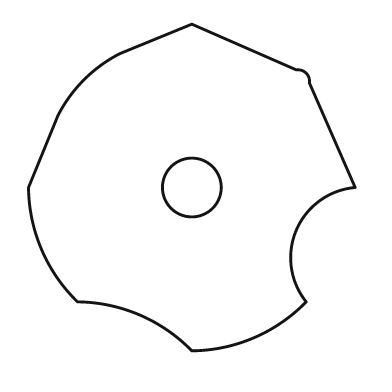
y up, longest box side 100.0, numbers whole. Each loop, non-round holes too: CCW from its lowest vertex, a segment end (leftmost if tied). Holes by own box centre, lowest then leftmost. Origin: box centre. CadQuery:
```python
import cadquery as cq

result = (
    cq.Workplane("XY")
    .moveTo(0.0, -50.0)
    .threePointArc((19.0, -46.0), (35.0, -35.0))
    .threePointArc((32.0, -13.0), (50.0, 0.0))
    .lineTo(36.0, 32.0)
    .threePointArc((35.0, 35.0), (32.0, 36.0))
    .lineTo(0.0, 50.0)
    .lineTo(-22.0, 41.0)
    .threePointArc((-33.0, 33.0), (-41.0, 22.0))
    .lineTo(-50.0, 0.0)
    .threePointArc((-46.0, -19.0), (-35.0, -35.0))
    .threePointArc((-16.0, -39.0), (0.0, -50.0))
    .close()
    .moveTo(0.0, 0.0)
    .circle(9.0)
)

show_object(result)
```